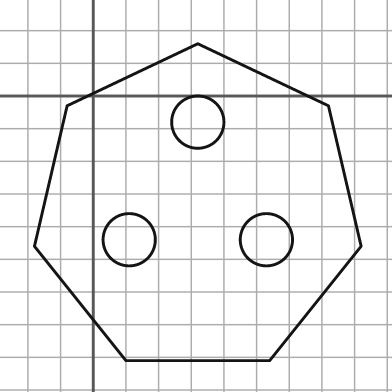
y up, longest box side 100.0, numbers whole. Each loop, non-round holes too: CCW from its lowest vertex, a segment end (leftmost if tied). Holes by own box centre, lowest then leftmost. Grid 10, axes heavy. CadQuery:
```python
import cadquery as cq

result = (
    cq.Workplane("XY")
    .moveTo(10.0, -81.0)
    .lineTo(54.0, -81.0)
    .lineTo(82.0, -46.0)
    .lineTo(72.0, -3.0)
    .lineTo(32.0, 16.0)
    .lineTo(-8.0, -3.0)
    .lineTo(-18.0, -46.0)
    .close()
    .moveTo(11.0, -44.0)
    .circle(8.0)
    .moveTo(53.0, -44.0)
    .circle(8.0)
    .moveTo(32.0, -8.0)
    .circle(8.0)
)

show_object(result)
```